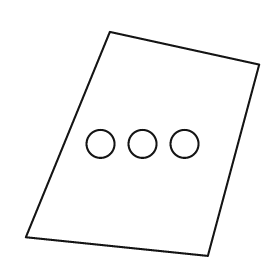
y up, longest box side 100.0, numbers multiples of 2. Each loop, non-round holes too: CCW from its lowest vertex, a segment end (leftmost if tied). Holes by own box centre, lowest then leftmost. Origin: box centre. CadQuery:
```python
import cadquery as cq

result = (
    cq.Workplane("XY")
    .moveTo(28.0, -48.0)
    .lineTo(50.0, 34.0)
    .lineTo(-14.0, 48.0)
    .lineTo(-50.0, -40.0)
    .close()
    .moveTo(-18.0, 0.0)
    .circle(6.0)
    .moveTo(0.0, 0.0)
    .circle(6.0)
    .moveTo(18.0, 0.0)
    .circle(6.0)
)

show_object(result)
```